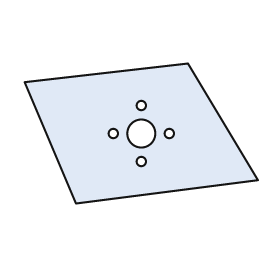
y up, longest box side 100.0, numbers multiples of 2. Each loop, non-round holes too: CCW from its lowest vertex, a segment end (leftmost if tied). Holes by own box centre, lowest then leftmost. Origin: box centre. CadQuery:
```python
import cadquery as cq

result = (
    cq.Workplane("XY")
    .moveTo(-28.0, -30.0)
    .lineTo(50.0, -20.0)
    .lineTo(20.0, 30.0)
    .lineTo(-50.0, 22.0)
    .close()
    .moveTo(0.0, -12.0)
    .circle(2.0)
    .moveTo(-12.0, 0.0)
    .circle(2.0)
    .moveTo(0.0, 0.0)
    .circle(6.0)
    .moveTo(12.0, 0.0)
    .circle(2.0)
    .moveTo(0.0, 12.0)
    .circle(2.0)
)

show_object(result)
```